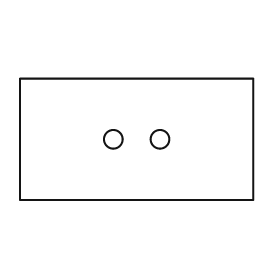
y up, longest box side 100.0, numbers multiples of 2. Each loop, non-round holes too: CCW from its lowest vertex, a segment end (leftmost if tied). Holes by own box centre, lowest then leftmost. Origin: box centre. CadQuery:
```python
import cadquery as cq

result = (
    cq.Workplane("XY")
    .moveTo(-50.0, -26.0)
    .lineTo(50.0, -26.0)
    .lineTo(50.0, 26.0)
    .lineTo(-50.0, 26.0)
    .close()
    .moveTo(-10.0, 0.0)
    .circle(4.0)
    .moveTo(10.0, 0.0)
    .circle(4.0)
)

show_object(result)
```